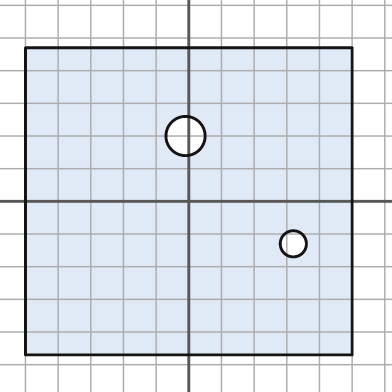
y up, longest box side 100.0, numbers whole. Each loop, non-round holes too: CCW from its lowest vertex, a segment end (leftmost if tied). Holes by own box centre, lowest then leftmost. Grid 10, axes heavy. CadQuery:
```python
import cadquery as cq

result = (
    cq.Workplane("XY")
    .moveTo(-50.0, -47.0)
    .lineTo(50.0, -47.0)
    .lineTo(50.0, 47.0)
    .lineTo(-50.0, 47.0)
    .close()
    .moveTo(32.0, -13.0)
    .circle(4.0)
    .moveTo(-1.0, 20.0)
    .circle(6.0)
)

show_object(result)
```